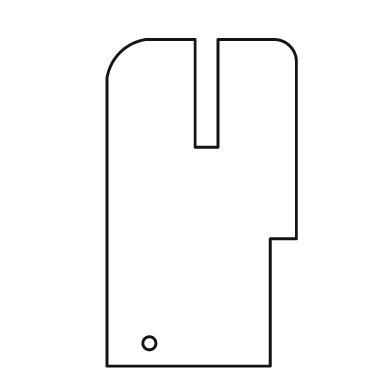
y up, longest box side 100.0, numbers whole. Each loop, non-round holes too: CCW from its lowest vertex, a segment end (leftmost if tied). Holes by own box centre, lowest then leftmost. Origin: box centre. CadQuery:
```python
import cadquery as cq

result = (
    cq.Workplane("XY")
    .moveTo(-29.0, -50.0)
    .lineTo(21.0, -50.0)
    .lineTo(21.0, -11.0)
    .lineTo(29.0, -11.0)
    .lineTo(29.0, 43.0)
    .threePointArc((27.0, 48.0), (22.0, 50.0))
    .lineTo(5.0, 50.0)
    .lineTo(5.0, 17.0)
    .lineTo(-2.0, 17.0)
    .lineTo(-2.0, 50.0)
    .lineTo(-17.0, 50.0)
    .threePointArc((-25.0, 46.0), (-29.0, 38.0))
    .close()
    .moveTo(-16.0, -43.0)
    .circle(2.0)
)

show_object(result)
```